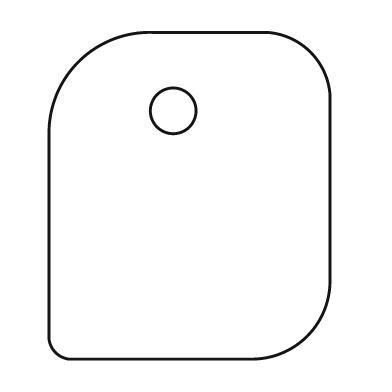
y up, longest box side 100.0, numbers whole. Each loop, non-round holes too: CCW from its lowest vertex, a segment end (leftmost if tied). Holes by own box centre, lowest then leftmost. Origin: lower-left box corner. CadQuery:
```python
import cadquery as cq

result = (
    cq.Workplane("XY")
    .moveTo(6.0, 0.0)
    .lineTo(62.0, 0.0)
    .threePointArc((79.0, 7.0), (86.0, 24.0))
    .lineTo(86.0, 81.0)
    .threePointArc((80.0, 94.0), (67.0, 100.0))
    .lineTo(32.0, 100.0)
    .threePointArc((9.0, 91.0), (0.0, 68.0))
    .lineTo(0.0, 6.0)
    .threePointArc((2.0, 2.0), (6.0, 0.0))
    .close()
    .moveTo(38.0, 76.0)
    .circle(7.0)
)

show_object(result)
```